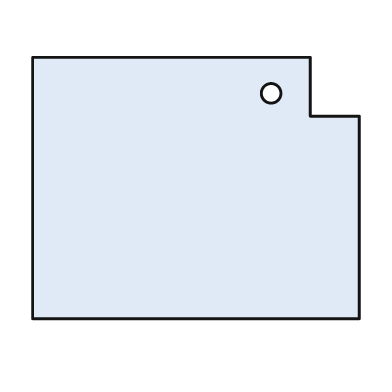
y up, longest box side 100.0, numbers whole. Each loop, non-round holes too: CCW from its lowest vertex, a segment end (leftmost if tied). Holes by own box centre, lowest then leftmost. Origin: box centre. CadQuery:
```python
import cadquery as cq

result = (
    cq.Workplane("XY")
    .moveTo(-50.0, -40.0)
    .lineTo(50.0, -40.0)
    .lineTo(50.0, 22.0)
    .lineTo(35.0, 22.0)
    .lineTo(35.0, 40.0)
    .lineTo(-50.0, 40.0)
    .close()
    .moveTo(23.0, 29.0)
    .circle(3.0)
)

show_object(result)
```